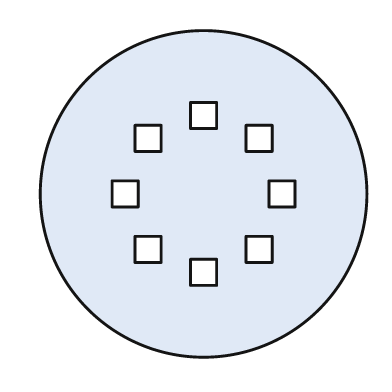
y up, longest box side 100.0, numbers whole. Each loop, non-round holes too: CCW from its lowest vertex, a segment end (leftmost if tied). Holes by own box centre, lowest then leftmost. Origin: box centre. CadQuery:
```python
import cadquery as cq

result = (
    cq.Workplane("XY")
    .moveTo(0.0, 0.0)
    .circle(50.0)
    .moveTo(-4.0, -28.0)
    .lineTo(4.0, -28.0)
    .lineTo(4.0, -20.0)
    .lineTo(-4.0, -20.0)
    .close()
    .moveTo(-21.0, -21.0)
    .lineTo(-13.0, -21.0)
    .lineTo(-13.0, -13.0)
    .lineTo(-21.0, -13.0)
    .close()
    .moveTo(13.0, -21.0)
    .lineTo(21.0, -21.0)
    .lineTo(21.0, -13.0)
    .lineTo(13.0, -13.0)
    .close()
    .moveTo(-28.0, -4.0)
    .lineTo(-20.0, -4.0)
    .lineTo(-20.0, 4.0)
    .lineTo(-28.0, 4.0)
    .close()
    .moveTo(20.0, -4.0)
    .lineTo(28.0, -4.0)
    .lineTo(28.0, 4.0)
    .lineTo(20.0, 4.0)
    .close()
    .moveTo(-21.0, 13.0)
    .lineTo(-13.0, 13.0)
    .lineTo(-13.0, 21.0)
    .lineTo(-21.0, 21.0)
    .close()
    .moveTo(13.0, 13.0)
    .lineTo(21.0, 13.0)
    .lineTo(21.0, 21.0)
    .lineTo(13.0, 21.0)
    .close()
    .moveTo(-4.0, 20.0)
    .lineTo(4.0, 20.0)
    .lineTo(4.0, 28.0)
    .lineTo(-4.0, 28.0)
    .close()
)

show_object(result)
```